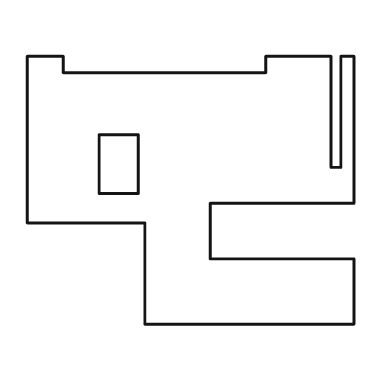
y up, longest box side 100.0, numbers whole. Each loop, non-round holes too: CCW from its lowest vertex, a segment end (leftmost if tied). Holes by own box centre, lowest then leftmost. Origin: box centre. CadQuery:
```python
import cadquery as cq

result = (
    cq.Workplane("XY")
    .moveTo(-14.0, -41.0)
    .lineTo(50.0, -41.0)
    .lineTo(50.0, -21.0)
    .lineTo(6.0, -21.0)
    .lineTo(6.0, -4.0)
    .lineTo(50.0, -4.0)
    .lineTo(50.0, 41.0)
    .lineTo(46.0, 41.0)
    .lineTo(46.0, 7.0)
    .lineTo(43.0, 7.0)
    .lineTo(43.0, 41.0)
    .lineTo(23.0, 41.0)
    .lineTo(23.0, 36.0)
    .lineTo(-39.0, 36.0)
    .lineTo(-39.0, 41.0)
    .lineTo(-50.0, 41.0)
    .lineTo(-50.0, -10.0)
    .lineTo(-14.0, -10.0)
    .close()
    .moveTo(-28.0, -1.0)
    .lineTo(-16.0, -1.0)
    .lineTo(-16.0, 17.0)
    .lineTo(-28.0, 17.0)
    .close()
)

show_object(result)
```